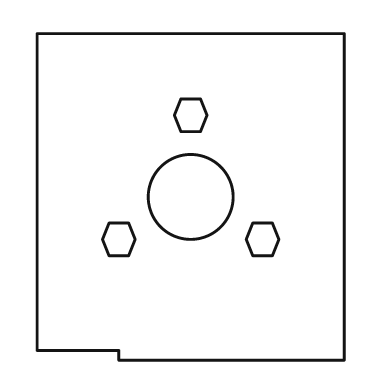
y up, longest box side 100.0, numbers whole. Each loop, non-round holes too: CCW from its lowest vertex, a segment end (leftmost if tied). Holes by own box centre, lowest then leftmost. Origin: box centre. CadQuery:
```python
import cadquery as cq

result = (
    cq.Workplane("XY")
    .moveTo(-22.0, -50.0)
    .lineTo(47.0, -50.0)
    .lineTo(47.0, 50.0)
    .lineTo(-47.0, 50.0)
    .lineTo(-47.0, -47.0)
    .lineTo(-22.0, -47.0)
    .close()
    .moveTo(-25.0, -18.0)
    .lineTo(-19.0, -18.0)
    .lineTo(-17.0, -13.0)
    .lineTo(-19.0, -8.0)
    .lineTo(-25.0, -8.0)
    .lineTo(-27.0, -13.0)
    .close()
    .moveTo(19.0, -18.0)
    .lineTo(25.0, -18.0)
    .lineTo(27.0, -13.0)
    .lineTo(25.0, -8.0)
    .lineTo(19.0, -8.0)
    .lineTo(17.0, -13.0)
    .close()
    .moveTo(0.0, 0.0)
    .circle(13.0)
    .moveTo(-3.0, 20.0)
    .lineTo(3.0, 20.0)
    .lineTo(5.0, 25.0)
    .lineTo(3.0, 30.0)
    .lineTo(-3.0, 30.0)
    .lineTo(-5.0, 25.0)
    .close()
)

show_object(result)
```